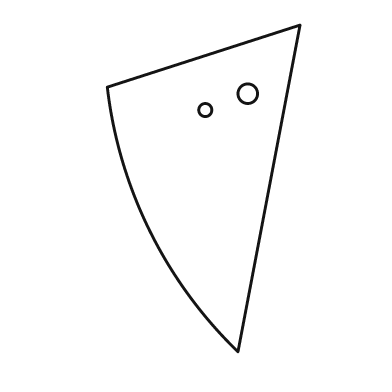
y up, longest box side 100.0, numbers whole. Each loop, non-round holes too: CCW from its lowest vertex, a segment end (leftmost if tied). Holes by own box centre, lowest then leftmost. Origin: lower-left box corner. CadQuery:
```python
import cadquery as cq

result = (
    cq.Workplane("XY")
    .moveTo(40.0, 0.0)
    .lineTo(59.0, 100.0)
    .lineTo(0.0, 81.0)
    .threePointArc((13.0, 37.0), (40.0, 0.0))
    .close()
    .moveTo(30.0, 74.0)
    .circle(2.0)
    .moveTo(43.0, 79.0)
    .circle(3.0)
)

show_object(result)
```